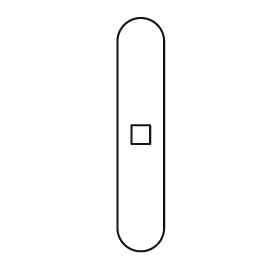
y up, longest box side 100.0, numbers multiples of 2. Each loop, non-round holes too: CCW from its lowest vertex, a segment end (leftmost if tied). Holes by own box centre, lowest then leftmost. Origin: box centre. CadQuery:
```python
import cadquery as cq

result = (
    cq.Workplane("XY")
    .moveTo(-10.0, -40.0)
    .threePointArc((0.0, -50.0), (10.0, -40.0))
    .lineTo(10.0, 40.0)
    .threePointArc((0.0, 50.0), (-10.0, 40.0))
    .close()
    .moveTo(-4.0, -4.0)
    .lineTo(4.0, -4.0)
    .lineTo(4.0, 4.0)
    .lineTo(-4.0, 4.0)
    .close()
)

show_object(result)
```